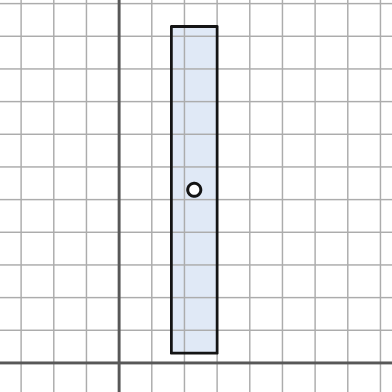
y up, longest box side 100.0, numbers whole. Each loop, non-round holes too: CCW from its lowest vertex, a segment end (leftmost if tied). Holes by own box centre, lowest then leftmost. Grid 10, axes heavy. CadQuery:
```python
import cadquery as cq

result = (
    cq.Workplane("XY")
    .moveTo(16.0, 3.0)
    .lineTo(30.0, 3.0)
    .lineTo(30.0, 103.0)
    .lineTo(16.0, 103.0)
    .close()
    .moveTo(23.0, 53.0)
    .circle(2.0)
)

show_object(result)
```